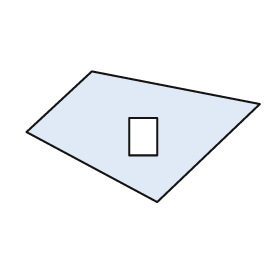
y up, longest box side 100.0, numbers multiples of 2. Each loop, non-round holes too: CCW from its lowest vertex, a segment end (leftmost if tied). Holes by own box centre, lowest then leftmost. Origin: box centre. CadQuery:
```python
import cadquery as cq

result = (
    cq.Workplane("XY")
    .moveTo(6.0, -28.0)
    .lineTo(50.0, 14.0)
    .lineTo(-22.0, 28.0)
    .lineTo(-50.0, 2.0)
    .close()
    .moveTo(-6.0, -8.0)
    .lineTo(6.0, -8.0)
    .lineTo(6.0, 8.0)
    .lineTo(-6.0, 8.0)
    .close()
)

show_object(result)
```